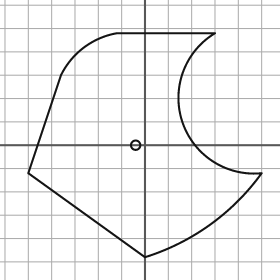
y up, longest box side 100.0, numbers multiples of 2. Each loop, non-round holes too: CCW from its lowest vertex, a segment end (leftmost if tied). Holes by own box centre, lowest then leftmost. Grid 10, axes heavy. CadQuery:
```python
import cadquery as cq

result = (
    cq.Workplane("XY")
    .moveTo(0.0, -48.0)
    .threePointArc((28.0, -34.0), (50.0, -12.0))
    .threePointArc((16.0, 10.0), (30.0, 48.0))
    .lineTo(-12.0, 48.0)
    .threePointArc((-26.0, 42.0), (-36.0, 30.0))
    .lineTo(-50.0, -12.0)
    .close()
    .moveTo(-4.0, 0.0)
    .circle(2.0)
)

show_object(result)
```